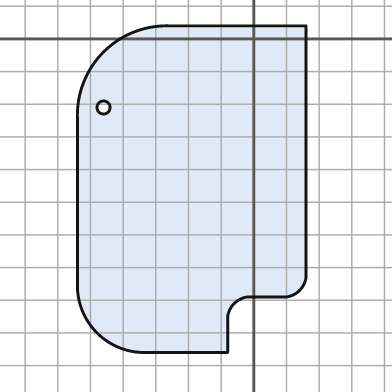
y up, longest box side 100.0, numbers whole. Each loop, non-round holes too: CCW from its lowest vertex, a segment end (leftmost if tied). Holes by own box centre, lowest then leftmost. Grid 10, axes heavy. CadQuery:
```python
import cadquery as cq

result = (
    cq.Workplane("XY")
    .moveTo(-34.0, -96.0)
    .lineTo(-8.0, -96.0)
    .lineTo(-8.0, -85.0)
    .threePointArc((-6.0, -81.0), (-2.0, -79.0))
    .lineTo(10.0, -79.0)
    .threePointArc((14.0, -77.0), (16.0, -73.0))
    .lineTo(16.0, 4.0)
    .lineTo(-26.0, 4.0)
    .threePointArc((-46.0, -4.0), (-54.0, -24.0))
    .lineTo(-54.0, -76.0)
    .threePointArc((-48.0, -90.0), (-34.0, -96.0))
    .close()
    .moveTo(-46.0, -21.0)
    .circle(2.0)
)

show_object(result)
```